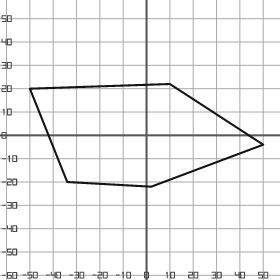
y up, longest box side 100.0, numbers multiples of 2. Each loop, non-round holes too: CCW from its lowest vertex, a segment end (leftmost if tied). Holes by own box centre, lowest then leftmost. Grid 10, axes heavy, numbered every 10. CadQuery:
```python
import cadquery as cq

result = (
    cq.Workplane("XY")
    .moveTo(2.0, -22.0)
    .lineTo(50.0, -4.0)
    .lineTo(10.0, 22.0)
    .lineTo(-50.0, 20.0)
    .lineTo(-34.0, -20.0)
    .close()
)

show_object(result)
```